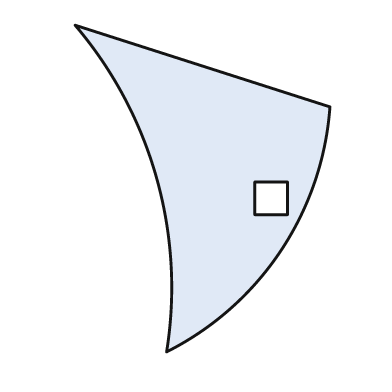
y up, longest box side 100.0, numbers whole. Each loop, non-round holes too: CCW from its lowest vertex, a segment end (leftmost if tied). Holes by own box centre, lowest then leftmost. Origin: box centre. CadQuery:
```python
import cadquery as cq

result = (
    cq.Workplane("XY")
    .moveTo(-11.0, -50.0)
    .threePointArc((24.0, -19.0), (39.0, 25.0))
    .lineTo(-39.0, 50.0)
    .threePointArc((-14.0, 3.0), (-11.0, -50.0))
    .close()
    .moveTo(16.0, -8.0)
    .lineTo(26.0, -8.0)
    .lineTo(26.0, 2.0)
    .lineTo(16.0, 2.0)
    .close()
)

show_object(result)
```